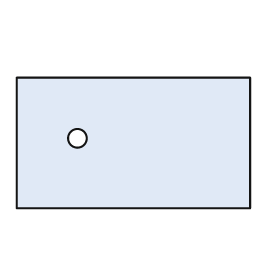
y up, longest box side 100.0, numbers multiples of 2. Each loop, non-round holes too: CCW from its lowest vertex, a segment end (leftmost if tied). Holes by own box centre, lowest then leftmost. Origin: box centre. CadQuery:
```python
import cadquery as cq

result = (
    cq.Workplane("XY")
    .moveTo(-50.0, -28.0)
    .lineTo(50.0, -28.0)
    .lineTo(50.0, 28.0)
    .lineTo(-50.0, 28.0)
    .close()
    .moveTo(-24.0, 2.0)
    .circle(4.0)
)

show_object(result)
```